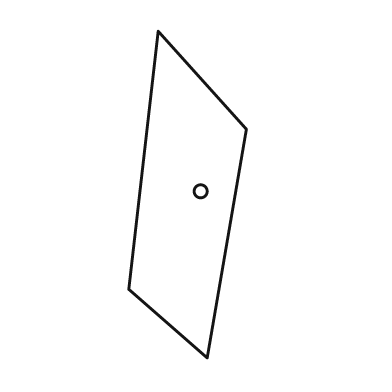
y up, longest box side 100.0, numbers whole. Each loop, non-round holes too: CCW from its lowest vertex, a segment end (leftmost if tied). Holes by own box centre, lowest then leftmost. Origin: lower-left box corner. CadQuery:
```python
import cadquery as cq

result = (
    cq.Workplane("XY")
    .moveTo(24.0, 0.0)
    .lineTo(36.0, 70.0)
    .lineTo(9.0, 100.0)
    .lineTo(0.0, 21.0)
    .close()
    .moveTo(22.0, 51.0)
    .circle(2.0)
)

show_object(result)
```